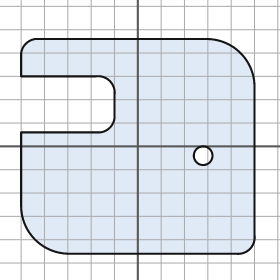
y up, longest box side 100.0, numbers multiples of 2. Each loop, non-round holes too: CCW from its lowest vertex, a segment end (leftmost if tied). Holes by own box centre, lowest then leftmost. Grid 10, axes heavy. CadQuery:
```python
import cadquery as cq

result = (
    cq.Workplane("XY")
    .moveTo(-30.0, -46.0)
    .lineTo(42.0, -46.0)
    .threePointArc((48.0, -44.0), (50.0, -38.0))
    .lineTo(50.0, 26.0)
    .threePointArc((44.0, 40.0), (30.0, 46.0))
    .lineTo(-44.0, 46.0)
    .threePointArc((-48.0, 44.0), (-50.0, 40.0))
    .lineTo(-50.0, 30.0)
    .lineTo(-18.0, 30.0)
    .threePointArc((-12.0, 28.0), (-10.0, 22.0))
    .lineTo(-10.0, 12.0)
    .threePointArc((-12.0, 8.0), (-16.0, 6.0))
    .lineTo(-50.0, 6.0)
    .lineTo(-50.0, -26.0)
    .threePointArc((-44.0, -40.0), (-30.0, -46.0))
    .close()
    .moveTo(28.0, -4.0)
    .circle(4.0)
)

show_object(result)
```